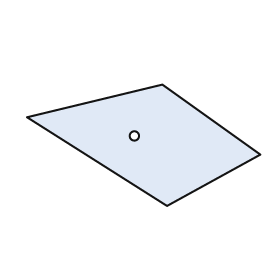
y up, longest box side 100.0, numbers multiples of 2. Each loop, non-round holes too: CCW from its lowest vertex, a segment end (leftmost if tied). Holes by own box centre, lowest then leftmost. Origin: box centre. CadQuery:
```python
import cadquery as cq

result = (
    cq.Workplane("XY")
    .moveTo(10.0, -26.0)
    .lineTo(50.0, -4.0)
    .lineTo(8.0, 26.0)
    .lineTo(-50.0, 12.0)
    .close()
    .moveTo(-4.0, 4.0)
    .circle(2.0)
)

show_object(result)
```